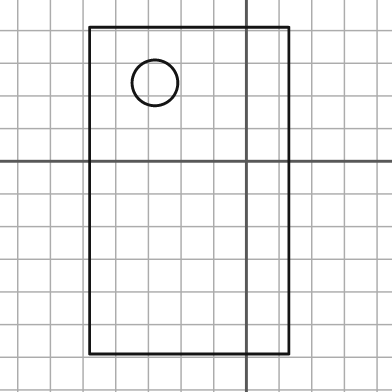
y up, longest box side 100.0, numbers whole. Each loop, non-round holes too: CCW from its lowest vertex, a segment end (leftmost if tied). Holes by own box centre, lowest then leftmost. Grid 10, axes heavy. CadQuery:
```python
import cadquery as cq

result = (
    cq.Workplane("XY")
    .moveTo(-48.0, -59.0)
    .lineTo(13.0, -59.0)
    .lineTo(13.0, 41.0)
    .lineTo(-48.0, 41.0)
    .close()
    .moveTo(-28.0, 24.0)
    .circle(7.0)
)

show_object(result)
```